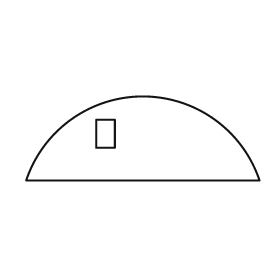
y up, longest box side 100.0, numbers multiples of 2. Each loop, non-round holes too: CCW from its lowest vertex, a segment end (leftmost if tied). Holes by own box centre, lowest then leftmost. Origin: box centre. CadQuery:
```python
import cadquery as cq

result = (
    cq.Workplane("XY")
    .moveTo(-50.0, -18.0)
    .lineTo(50.0, -18.0)
    .threePointArc((0.0, 18.0), (-50.0, -18.0))
    .close()
    .moveTo(-20.0, -4.0)
    .lineTo(-12.0, -4.0)
    .lineTo(-12.0, 8.0)
    .lineTo(-20.0, 8.0)
    .close()
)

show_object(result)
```